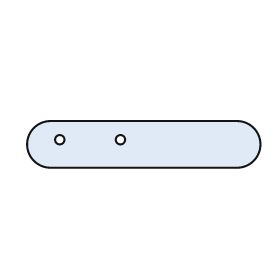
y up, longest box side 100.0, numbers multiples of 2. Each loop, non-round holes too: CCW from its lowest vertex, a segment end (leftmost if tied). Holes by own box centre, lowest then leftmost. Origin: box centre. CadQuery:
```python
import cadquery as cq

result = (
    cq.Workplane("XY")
    .moveTo(-40.0, -10.0)
    .lineTo(40.0, -10.0)
    .threePointArc((50.0, 0.0), (40.0, 10.0))
    .lineTo(-40.0, 10.0)
    .threePointArc((-50.0, 0.0), (-40.0, -10.0))
    .close()
    .moveTo(-36.0, 2.0)
    .circle(2.0)
    .moveTo(-10.0, 2.0)
    .circle(2.0)
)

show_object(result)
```